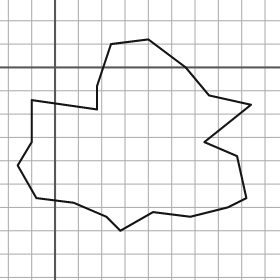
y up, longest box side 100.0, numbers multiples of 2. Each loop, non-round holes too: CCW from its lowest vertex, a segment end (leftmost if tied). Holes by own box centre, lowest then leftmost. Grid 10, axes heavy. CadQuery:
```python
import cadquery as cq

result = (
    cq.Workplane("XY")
    .moveTo(28.0, -70.0)
    .lineTo(42.0, -62.0)
    .lineTo(58.0, -64.0)
    .lineTo(74.0, -60.0)
    .lineTo(82.0, -56.0)
    .lineTo(78.0, -38.0)
    .lineTo(64.0, -32.0)
    .lineTo(84.0, -16.0)
    .lineTo(66.0, -12.0)
    .lineTo(56.0, 0.0)
    .lineTo(40.0, 12.0)
    .lineTo(24.0, 10.0)
    .lineTo(18.0, -8.0)
    .lineTo(18.0, -18.0)
    .lineTo(-10.0, -14.0)
    .lineTo(-10.0, -32.0)
    .lineTo(-16.0, -42.0)
    .lineTo(-8.0, -56.0)
    .lineTo(8.0, -58.0)
    .lineTo(22.0, -64.0)
    .close()
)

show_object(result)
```